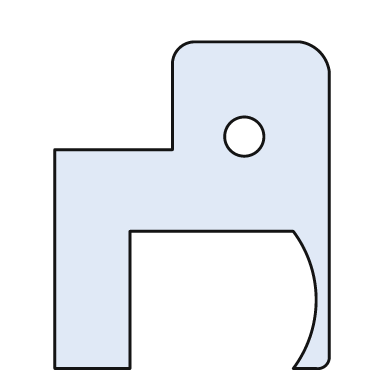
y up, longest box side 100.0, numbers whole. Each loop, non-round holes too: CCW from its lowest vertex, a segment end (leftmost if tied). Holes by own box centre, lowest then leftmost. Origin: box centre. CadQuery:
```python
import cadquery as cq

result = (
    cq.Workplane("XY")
    .moveTo(-42.0, -50.0)
    .lineTo(-19.0, -50.0)
    .lineTo(-19.0, -8.0)
    .lineTo(31.0, -8.0)
    .threePointArc((38.0, -29.0), (31.0, -50.0))
    .lineTo(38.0, -50.0)
    .threePointArc((41.0, -49.0), (42.0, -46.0))
    .lineTo(42.0, 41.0)
    .threePointArc((39.0, 47.0), (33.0, 50.0))
    .lineTo(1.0, 50.0)
    .threePointArc((-4.0, 48.0), (-6.0, 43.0))
    .lineTo(-6.0, 17.0)
    .lineTo(-42.0, 17.0)
    .close()
    .moveTo(16.0, 21.0)
    .circle(6.0)
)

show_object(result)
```